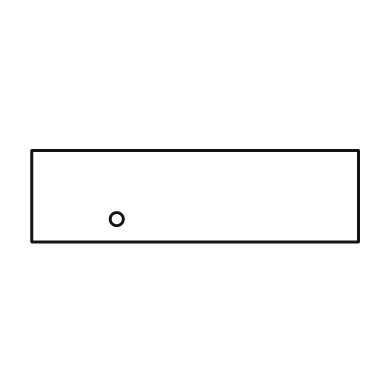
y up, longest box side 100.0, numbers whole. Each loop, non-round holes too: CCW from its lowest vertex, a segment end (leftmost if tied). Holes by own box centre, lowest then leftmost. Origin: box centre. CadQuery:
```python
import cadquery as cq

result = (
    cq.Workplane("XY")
    .moveTo(-50.0, -14.0)
    .lineTo(50.0, -14.0)
    .lineTo(50.0, 14.0)
    .lineTo(-50.0, 14.0)
    .close()
    .moveTo(-24.0, -7.0)
    .circle(2.0)
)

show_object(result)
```